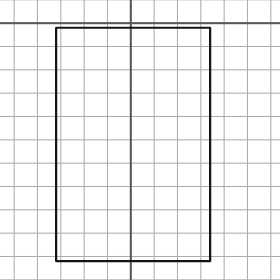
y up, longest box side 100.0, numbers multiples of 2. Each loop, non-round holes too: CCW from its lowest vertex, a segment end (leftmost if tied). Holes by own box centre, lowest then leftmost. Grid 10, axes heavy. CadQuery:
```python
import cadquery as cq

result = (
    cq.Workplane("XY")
    .moveTo(-32.0, -102.0)
    .lineTo(34.0, -102.0)
    .lineTo(34.0, -2.0)
    .lineTo(-32.0, -2.0)
    .close()
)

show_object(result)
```